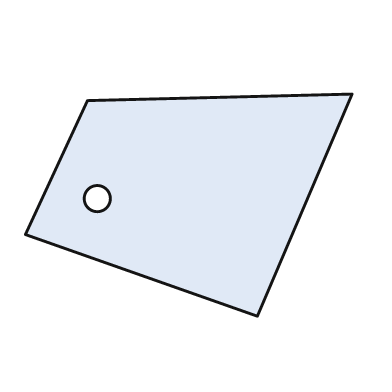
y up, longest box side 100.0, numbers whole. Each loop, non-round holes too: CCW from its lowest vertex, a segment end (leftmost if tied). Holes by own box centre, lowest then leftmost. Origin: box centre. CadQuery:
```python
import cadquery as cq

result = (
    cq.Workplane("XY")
    .moveTo(21.0, -34.0)
    .lineTo(50.0, 34.0)
    .lineTo(-31.0, 32.0)
    .lineTo(-50.0, -9.0)
    .close()
    .moveTo(-28.0, 2.0)
    .circle(4.0)
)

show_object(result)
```